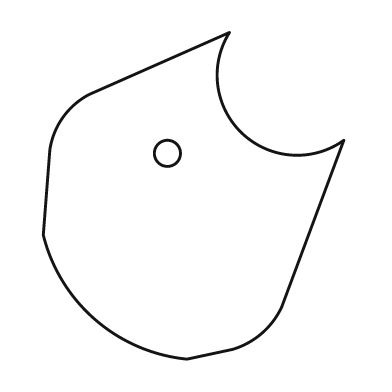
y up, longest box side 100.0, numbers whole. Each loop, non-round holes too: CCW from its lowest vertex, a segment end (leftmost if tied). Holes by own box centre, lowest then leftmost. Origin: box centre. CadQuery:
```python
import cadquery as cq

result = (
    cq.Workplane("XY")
    .moveTo(-2.0, -50.0)
    .lineTo(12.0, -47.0)
    .threePointArc((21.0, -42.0), (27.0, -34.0))
    .lineTo(46.0, 17.0)
    .threePointArc((15.0, 19.0), (11.0, 50.0))
    .lineTo(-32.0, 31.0)
    .threePointArc((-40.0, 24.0), (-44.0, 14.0))
    .lineTo(-46.0, -12.0)
    .threePointArc((-30.0, -38.0), (-2.0, -50.0))
    .close()
    .moveTo(-8.0, 13.0)
    .circle(4.0)
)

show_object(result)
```